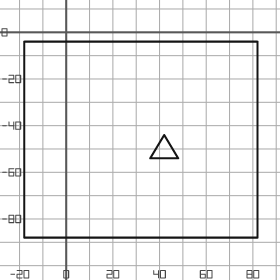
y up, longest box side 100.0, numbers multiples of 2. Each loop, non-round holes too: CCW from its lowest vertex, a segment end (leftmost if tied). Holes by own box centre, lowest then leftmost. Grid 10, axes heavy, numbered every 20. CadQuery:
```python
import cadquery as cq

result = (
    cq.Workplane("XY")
    .moveTo(-18.0, -88.0)
    .lineTo(82.0, -88.0)
    .lineTo(82.0, -4.0)
    .lineTo(-18.0, -4.0)
    .close()
    .moveTo(36.0, -54.0)
    .lineTo(48.0, -54.0)
    .lineTo(42.0, -44.0)
    .close()
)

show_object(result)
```